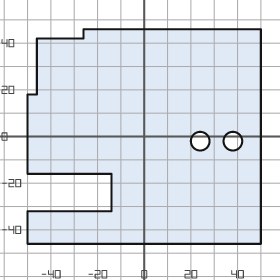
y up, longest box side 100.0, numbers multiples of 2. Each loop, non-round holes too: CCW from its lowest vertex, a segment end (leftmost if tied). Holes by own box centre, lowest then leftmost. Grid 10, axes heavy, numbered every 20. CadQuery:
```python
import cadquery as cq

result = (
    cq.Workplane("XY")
    .moveTo(-50.0, -46.0)
    .lineTo(50.0, -46.0)
    .lineTo(50.0, 46.0)
    .lineTo(-26.0, 46.0)
    .lineTo(-26.0, 42.0)
    .lineTo(-46.0, 42.0)
    .lineTo(-46.0, 18.0)
    .lineTo(-50.0, 18.0)
    .lineTo(-50.0, -16.0)
    .lineTo(-14.0, -16.0)
    .lineTo(-14.0, -32.0)
    .lineTo(-50.0, -32.0)
    .close()
    .moveTo(24.0, -2.0)
    .circle(4.0)
    .moveTo(38.0, -2.0)
    .circle(4.0)
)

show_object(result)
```